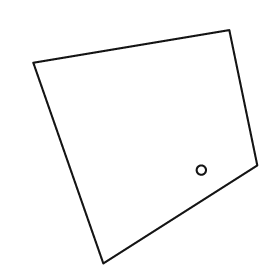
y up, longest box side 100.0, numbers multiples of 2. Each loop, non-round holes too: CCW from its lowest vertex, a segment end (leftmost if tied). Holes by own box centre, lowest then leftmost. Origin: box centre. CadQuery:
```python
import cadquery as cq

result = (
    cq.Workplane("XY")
    .moveTo(-18.0, -50.0)
    .lineTo(48.0, -8.0)
    .lineTo(36.0, 50.0)
    .lineTo(-48.0, 36.0)
    .close()
    .moveTo(24.0, -10.0)
    .circle(2.0)
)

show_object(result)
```